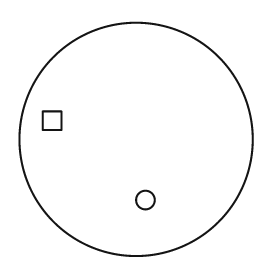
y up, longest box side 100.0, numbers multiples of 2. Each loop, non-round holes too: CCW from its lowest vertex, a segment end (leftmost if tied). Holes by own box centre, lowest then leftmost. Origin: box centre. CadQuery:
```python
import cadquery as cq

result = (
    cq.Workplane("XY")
    .moveTo(0.0, 0.0)
    .circle(50.0)
    .moveTo(4.0, -26.0)
    .circle(4.0)
    .moveTo(-40.0, 4.0)
    .lineTo(-32.0, 4.0)
    .lineTo(-32.0, 12.0)
    .lineTo(-40.0, 12.0)
    .close()
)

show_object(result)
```